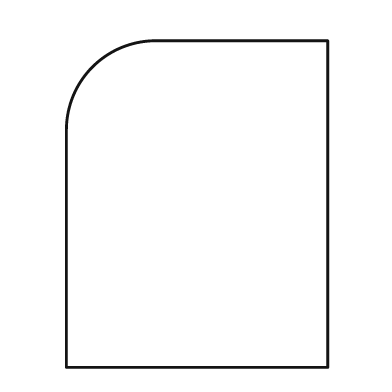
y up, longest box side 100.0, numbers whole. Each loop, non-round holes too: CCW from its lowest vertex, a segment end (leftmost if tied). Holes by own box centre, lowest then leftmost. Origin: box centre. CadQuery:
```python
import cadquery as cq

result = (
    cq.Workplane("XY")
    .moveTo(-40.0, -50.0)
    .lineTo(40.0, -50.0)
    .lineTo(40.0, 50.0)
    .lineTo(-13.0, 50.0)
    .threePointArc((-32.0, 42.0), (-40.0, 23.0))
    .close()
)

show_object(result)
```